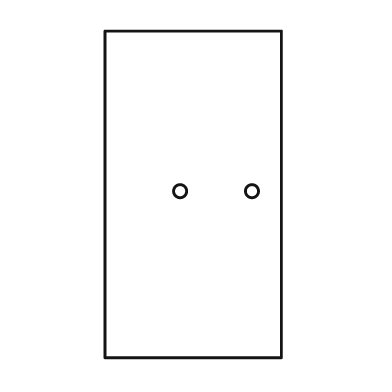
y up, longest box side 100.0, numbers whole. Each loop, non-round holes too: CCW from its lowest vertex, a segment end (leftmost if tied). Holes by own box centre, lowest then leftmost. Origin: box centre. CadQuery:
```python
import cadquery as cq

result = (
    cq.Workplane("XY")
    .moveTo(-27.0, -50.0)
    .lineTo(27.0, -50.0)
    .lineTo(27.0, 50.0)
    .lineTo(-27.0, 50.0)
    .close()
    .moveTo(-4.0, 1.0)
    .circle(2.0)
    .moveTo(18.0, 1.0)
    .circle(2.0)
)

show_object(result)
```